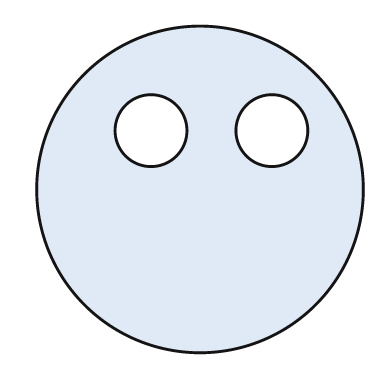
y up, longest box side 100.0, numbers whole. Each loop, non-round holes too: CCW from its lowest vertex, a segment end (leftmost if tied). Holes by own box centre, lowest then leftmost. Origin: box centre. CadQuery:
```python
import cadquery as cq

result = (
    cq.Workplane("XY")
    .moveTo(0.0, 0.0)
    .circle(50.0)
    .moveTo(-15.0, 18.0)
    .circle(11.0)
    .moveTo(22.0, 18.0)
    .circle(11.0)
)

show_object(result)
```